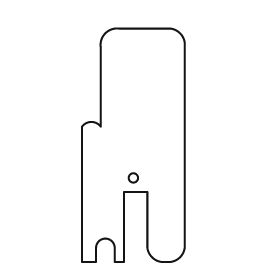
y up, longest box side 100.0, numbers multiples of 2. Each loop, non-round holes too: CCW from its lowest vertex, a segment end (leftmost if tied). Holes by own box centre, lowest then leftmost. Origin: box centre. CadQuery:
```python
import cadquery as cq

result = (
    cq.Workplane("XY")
    .moveTo(-22.0, -50.0)
    .lineTo(-16.0, -50.0)
    .lineTo(-16.0, -44.0)
    .threePointArc((-12.0, -40.0), (-8.0, -44.0))
    .lineTo(-8.0, -50.0)
    .lineTo(-4.0, -50.0)
    .lineTo(-4.0, -20.0)
    .lineTo(6.0, -20.0)
    .lineTo(6.0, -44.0)
    .threePointArc((8.0, -48.0), (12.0, -50.0))
    .lineTo(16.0, -50.0)
    .threePointArc((20.0, -48.0), (22.0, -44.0))
    .lineTo(22.0, 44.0)
    .threePointArc((20.0, 48.0), (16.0, 50.0))
    .lineTo(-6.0, 50.0)
    .threePointArc((-12.0, 48.0), (-14.0, 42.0))
    .lineTo(-14.0, 8.0)
    .threePointArc((-18.0, 10.0), (-22.0, 8.0))
    .close()
    .moveTo(0.0, -14.0)
    .circle(2.0)
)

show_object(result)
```